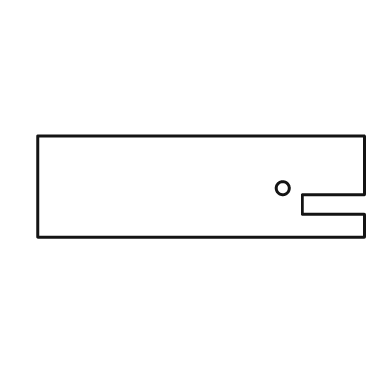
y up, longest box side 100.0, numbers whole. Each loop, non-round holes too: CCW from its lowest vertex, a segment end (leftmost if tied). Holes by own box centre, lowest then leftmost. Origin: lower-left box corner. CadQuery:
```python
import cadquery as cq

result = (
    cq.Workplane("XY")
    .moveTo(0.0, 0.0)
    .lineTo(100.0, 0.0)
    .lineTo(100.0, 7.0)
    .lineTo(81.0, 7.0)
    .lineTo(81.0, 13.0)
    .lineTo(100.0, 13.0)
    .lineTo(100.0, 31.0)
    .lineTo(0.0, 31.0)
    .close()
    .moveTo(75.0, 15.0)
    .circle(2.0)
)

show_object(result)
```